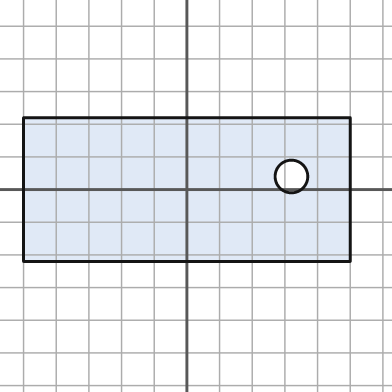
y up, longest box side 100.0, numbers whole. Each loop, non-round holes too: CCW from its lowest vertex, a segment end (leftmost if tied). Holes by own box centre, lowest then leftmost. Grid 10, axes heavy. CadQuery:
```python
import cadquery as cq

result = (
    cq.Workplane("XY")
    .moveTo(-50.0, -22.0)
    .lineTo(50.0, -22.0)
    .lineTo(50.0, 22.0)
    .lineTo(-50.0, 22.0)
    .close()
    .moveTo(32.0, 4.0)
    .circle(5.0)
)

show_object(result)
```